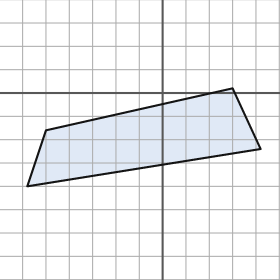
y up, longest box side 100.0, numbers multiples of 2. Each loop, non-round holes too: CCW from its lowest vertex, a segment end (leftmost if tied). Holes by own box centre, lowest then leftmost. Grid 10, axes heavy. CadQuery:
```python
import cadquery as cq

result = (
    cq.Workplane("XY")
    .moveTo(-58.0, -40.0)
    .lineTo(42.0, -24.0)
    .lineTo(30.0, 2.0)
    .lineTo(-50.0, -16.0)
    .close()
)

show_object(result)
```